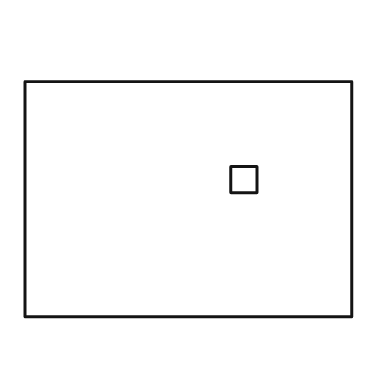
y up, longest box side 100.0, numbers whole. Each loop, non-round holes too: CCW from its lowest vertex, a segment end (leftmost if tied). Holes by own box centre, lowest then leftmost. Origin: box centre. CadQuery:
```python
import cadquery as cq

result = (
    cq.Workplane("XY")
    .moveTo(-50.0, -36.0)
    .lineTo(50.0, -36.0)
    .lineTo(50.0, 36.0)
    .lineTo(-50.0, 36.0)
    .close()
    .moveTo(13.0, 2.0)
    .lineTo(21.0, 2.0)
    .lineTo(21.0, 10.0)
    .lineTo(13.0, 10.0)
    .close()
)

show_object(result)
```